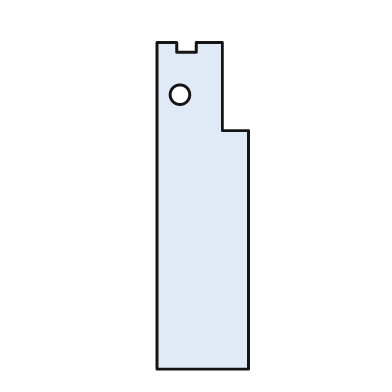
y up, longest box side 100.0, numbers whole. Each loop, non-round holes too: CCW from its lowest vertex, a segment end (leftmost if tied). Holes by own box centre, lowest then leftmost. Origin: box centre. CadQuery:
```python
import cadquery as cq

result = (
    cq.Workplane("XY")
    .moveTo(-14.0, -50.0)
    .lineTo(14.0, -50.0)
    .lineTo(14.0, 23.0)
    .lineTo(6.0, 23.0)
    .lineTo(6.0, 50.0)
    .lineTo(-2.0, 50.0)
    .lineTo(-2.0, 47.0)
    .lineTo(-8.0, 47.0)
    .lineTo(-8.0, 50.0)
    .lineTo(-14.0, 50.0)
    .close()
    .moveTo(-7.0, 34.0)
    .circle(3.0)
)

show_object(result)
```